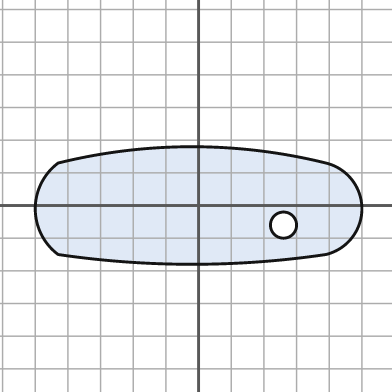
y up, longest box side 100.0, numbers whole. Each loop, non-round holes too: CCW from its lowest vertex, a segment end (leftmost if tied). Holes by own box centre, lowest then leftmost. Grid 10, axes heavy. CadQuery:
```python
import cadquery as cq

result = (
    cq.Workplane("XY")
    .moveTo(-43.0, -15.0)
    .threePointArc((-2.0, -18.0), (39.0, -15.0))
    .threePointArc((50.0, -1.0), (39.0, 13.0))
    .threePointArc((-2.0, 18.0), (-43.0, 13.0))
    .threePointArc((-50.0, -1.0), (-43.0, -15.0))
    .close()
    .moveTo(26.0, -6.0)
    .circle(4.0)
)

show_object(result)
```